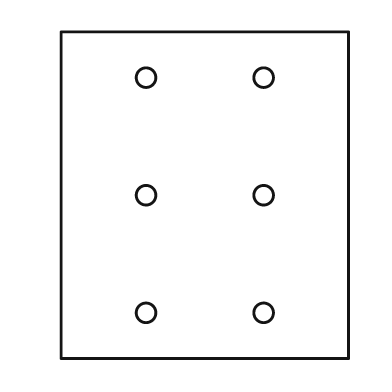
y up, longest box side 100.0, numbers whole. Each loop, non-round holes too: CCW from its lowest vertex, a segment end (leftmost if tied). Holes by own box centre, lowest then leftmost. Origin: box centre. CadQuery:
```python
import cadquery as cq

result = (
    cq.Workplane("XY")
    .moveTo(-44.0, -50.0)
    .lineTo(44.0, -50.0)
    .lineTo(44.0, 50.0)
    .lineTo(-44.0, 50.0)
    .close()
    .moveTo(-18.0, -36.0)
    .circle(3.0)
    .moveTo(18.0, -36.0)
    .circle(3.0)
    .moveTo(-18.0, 0.0)
    .circle(3.0)
    .moveTo(18.0, 0.0)
    .circle(3.0)
    .moveTo(-18.0, 36.0)
    .circle(3.0)
    .moveTo(18.0, 36.0)
    .circle(3.0)
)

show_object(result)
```